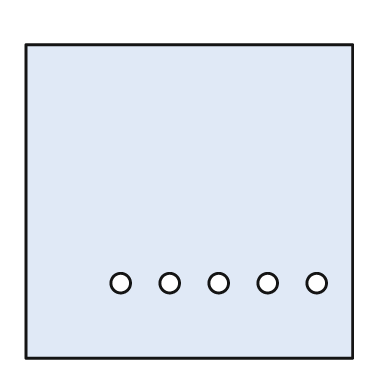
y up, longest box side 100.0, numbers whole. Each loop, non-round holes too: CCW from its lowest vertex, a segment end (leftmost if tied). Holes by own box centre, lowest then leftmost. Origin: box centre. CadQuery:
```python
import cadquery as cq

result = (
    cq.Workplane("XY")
    .moveTo(-50.0, -48.0)
    .lineTo(50.0, -48.0)
    .lineTo(50.0, 48.0)
    .lineTo(-50.0, 48.0)
    .close()
    .moveTo(-21.0, -25.0)
    .circle(3.0)
    .moveTo(-6.0, -25.0)
    .circle(3.0)
    .moveTo(9.0, -25.0)
    .circle(3.0)
    .moveTo(24.0, -25.0)
    .circle(3.0)
    .moveTo(39.0, -25.0)
    .circle(3.0)
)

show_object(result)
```